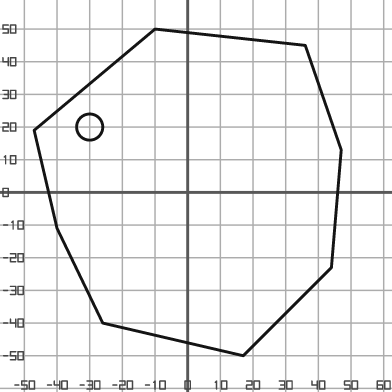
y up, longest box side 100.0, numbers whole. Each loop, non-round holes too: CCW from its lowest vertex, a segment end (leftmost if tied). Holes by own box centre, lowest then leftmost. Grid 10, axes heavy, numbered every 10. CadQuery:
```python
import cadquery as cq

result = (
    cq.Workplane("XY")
    .moveTo(17.0, -50.0)
    .lineTo(44.0, -23.0)
    .lineTo(47.0, 13.0)
    .lineTo(36.0, 45.0)
    .lineTo(-10.0, 50.0)
    .lineTo(-47.0, 19.0)
    .lineTo(-40.0, -11.0)
    .lineTo(-26.0, -40.0)
    .close()
    .moveTo(-30.0, 20.0)
    .circle(4.0)
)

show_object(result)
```